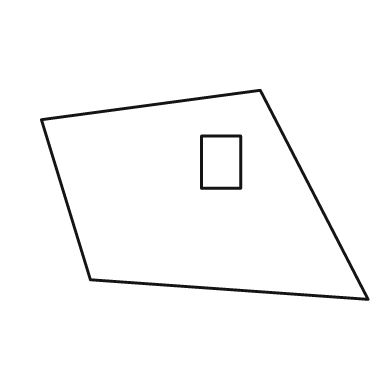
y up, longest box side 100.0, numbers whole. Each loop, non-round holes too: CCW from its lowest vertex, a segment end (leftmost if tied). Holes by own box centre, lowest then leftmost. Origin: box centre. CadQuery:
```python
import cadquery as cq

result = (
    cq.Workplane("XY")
    .moveTo(50.0, -32.0)
    .lineTo(17.0, 32.0)
    .lineTo(-50.0, 23.0)
    .lineTo(-35.0, -26.0)
    .close()
    .moveTo(-1.0, 2.0)
    .lineTo(11.0, 2.0)
    .lineTo(11.0, 18.0)
    .lineTo(-1.0, 18.0)
    .close()
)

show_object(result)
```